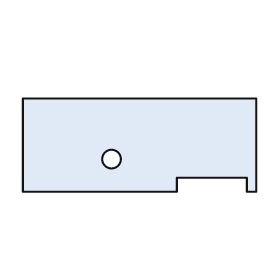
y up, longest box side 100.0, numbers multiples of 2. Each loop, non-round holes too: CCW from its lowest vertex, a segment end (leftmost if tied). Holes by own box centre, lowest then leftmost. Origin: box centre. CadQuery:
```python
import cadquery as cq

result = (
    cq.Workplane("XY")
    .moveTo(-50.0, -20.0)
    .lineTo(16.0, -20.0)
    .lineTo(16.0, -14.0)
    .lineTo(46.0, -14.0)
    .lineTo(46.0, -20.0)
    .lineTo(50.0, -20.0)
    .lineTo(50.0, 20.0)
    .lineTo(-50.0, 20.0)
    .close()
    .moveTo(-12.0, -6.0)
    .circle(4.0)
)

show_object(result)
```